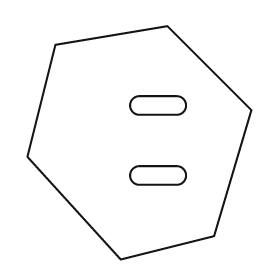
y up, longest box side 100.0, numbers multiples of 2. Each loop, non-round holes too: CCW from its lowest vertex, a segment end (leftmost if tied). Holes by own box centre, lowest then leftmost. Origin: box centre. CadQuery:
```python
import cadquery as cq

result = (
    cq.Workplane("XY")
    .moveTo(-8.0, -50.0)
    .lineTo(32.0, -40.0)
    .lineTo(48.0, 14.0)
    .lineTo(12.0, 50.0)
    .lineTo(-36.0, 42.0)
    .lineTo(-48.0, -6.0)
    .close()
    .moveTo(0.0, -18.0)
    .lineTo(16.0, -18.0)
    .threePointArc((20.0, -14.0), (16.0, -10.0))
    .lineTo(0.0, -10.0)
    .threePointArc((-4.0, -14.0), (0.0, -18.0))
    .close()
    .moveTo(0.0, 12.0)
    .lineTo(16.0, 12.0)
    .threePointArc((20.0, 16.0), (16.0, 20.0))
    .lineTo(0.0, 20.0)
    .threePointArc((-4.0, 16.0), (0.0, 12.0))
    .close()
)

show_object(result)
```